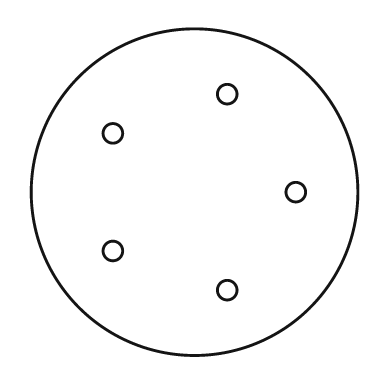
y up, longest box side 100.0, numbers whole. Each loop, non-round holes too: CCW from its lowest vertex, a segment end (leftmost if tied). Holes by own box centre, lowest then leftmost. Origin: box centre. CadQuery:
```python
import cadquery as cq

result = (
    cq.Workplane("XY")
    .moveTo(0.0, 0.0)
    .circle(50.0)
    .moveTo(10.0, -30.0)
    .circle(3.0)
    .moveTo(-25.0, -18.0)
    .circle(3.0)
    .moveTo(31.0, 0.0)
    .circle(3.0)
    .moveTo(-25.0, 18.0)
    .circle(3.0)
    .moveTo(10.0, 30.0)
    .circle(3.0)
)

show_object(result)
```